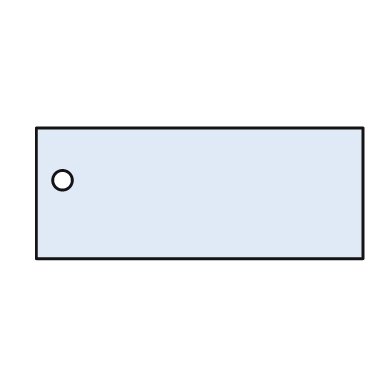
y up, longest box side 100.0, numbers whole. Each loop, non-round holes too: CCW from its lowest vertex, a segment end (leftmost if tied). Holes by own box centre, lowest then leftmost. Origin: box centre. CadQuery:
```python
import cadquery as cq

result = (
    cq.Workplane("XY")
    .moveTo(-50.0, -20.0)
    .lineTo(50.0, -20.0)
    .lineTo(50.0, 20.0)
    .lineTo(-50.0, 20.0)
    .close()
    .moveTo(-42.0, 4.0)
    .circle(3.0)
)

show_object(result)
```